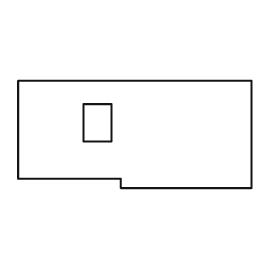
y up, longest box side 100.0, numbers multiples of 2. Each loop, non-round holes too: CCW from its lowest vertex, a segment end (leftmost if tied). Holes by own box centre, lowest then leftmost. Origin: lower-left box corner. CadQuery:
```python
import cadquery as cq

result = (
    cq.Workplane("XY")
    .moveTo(44.0, 0.0)
    .lineTo(100.0, 0.0)
    .lineTo(100.0, 46.0)
    .lineTo(0.0, 46.0)
    .lineTo(0.0, 4.0)
    .lineTo(44.0, 4.0)
    .close()
    .moveTo(28.0, 20.0)
    .lineTo(40.0, 20.0)
    .lineTo(40.0, 36.0)
    .lineTo(28.0, 36.0)
    .close()
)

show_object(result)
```